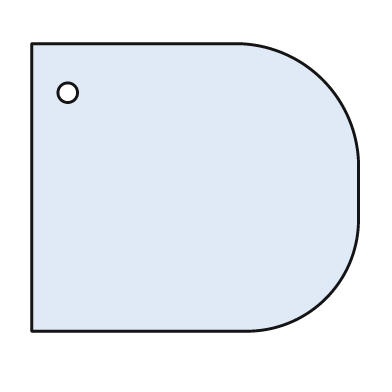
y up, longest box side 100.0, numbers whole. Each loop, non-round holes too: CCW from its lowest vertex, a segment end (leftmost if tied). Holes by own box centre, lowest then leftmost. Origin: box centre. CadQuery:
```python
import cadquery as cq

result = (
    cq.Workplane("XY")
    .moveTo(-50.0, -44.0)
    .lineTo(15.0, -44.0)
    .threePointArc((40.0, -34.0), (50.0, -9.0))
    .lineTo(50.0, 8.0)
    .threePointArc((39.0, 33.0), (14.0, 44.0))
    .lineTo(-50.0, 44.0)
    .close()
    .moveTo(-39.0, 29.0)
    .circle(3.0)
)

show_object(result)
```